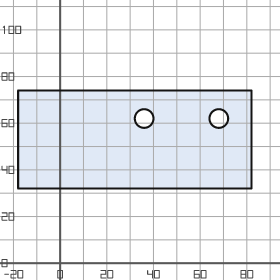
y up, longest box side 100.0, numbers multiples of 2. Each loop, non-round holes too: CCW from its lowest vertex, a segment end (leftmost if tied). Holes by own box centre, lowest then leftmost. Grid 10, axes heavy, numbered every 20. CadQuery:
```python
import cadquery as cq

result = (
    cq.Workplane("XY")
    .moveTo(-18.0, 32.0)
    .lineTo(82.0, 32.0)
    .lineTo(82.0, 74.0)
    .lineTo(-18.0, 74.0)
    .close()
    .moveTo(36.0, 62.0)
    .circle(4.0)
    .moveTo(68.0, 62.0)
    .circle(4.0)
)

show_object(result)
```